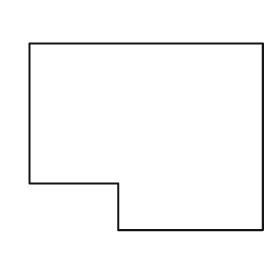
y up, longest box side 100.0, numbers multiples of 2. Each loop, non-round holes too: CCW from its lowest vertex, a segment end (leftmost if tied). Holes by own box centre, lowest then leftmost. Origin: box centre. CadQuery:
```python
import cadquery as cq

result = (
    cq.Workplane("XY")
    .moveTo(-12.0, -40.0)
    .lineTo(50.0, -40.0)
    .lineTo(50.0, 40.0)
    .lineTo(-50.0, 40.0)
    .lineTo(-50.0, -20.0)
    .lineTo(-12.0, -20.0)
    .close()
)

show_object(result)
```